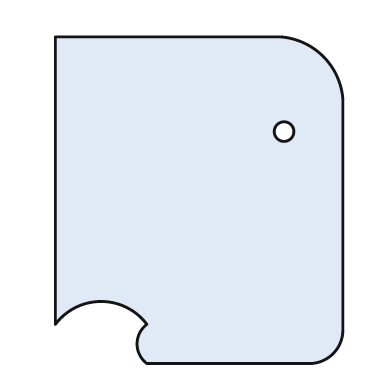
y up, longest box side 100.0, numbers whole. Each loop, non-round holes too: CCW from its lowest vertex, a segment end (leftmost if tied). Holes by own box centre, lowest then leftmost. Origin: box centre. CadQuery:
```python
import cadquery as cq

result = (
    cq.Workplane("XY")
    .moveTo(-16.0, -50.0)
    .lineTo(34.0, -50.0)
    .threePointArc((41.0, -47.0), (44.0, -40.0))
    .lineTo(44.0, 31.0)
    .threePointArc((38.0, 44.0), (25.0, 50.0))
    .lineTo(-44.0, 50.0)
    .lineTo(-44.0, -38.0)
    .threePointArc((-30.0, -31.0), (-16.0, -38.0))
    .threePointArc((-19.0, -44.0), (-16.0, -50.0))
    .close()
    .moveTo(26.0, 21.0)
    .circle(3.0)
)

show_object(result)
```